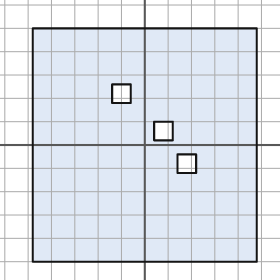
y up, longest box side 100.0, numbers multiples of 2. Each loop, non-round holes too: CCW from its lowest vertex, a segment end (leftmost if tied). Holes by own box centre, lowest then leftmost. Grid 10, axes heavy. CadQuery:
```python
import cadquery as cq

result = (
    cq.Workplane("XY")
    .moveTo(-48.0, -50.0)
    .lineTo(48.0, -50.0)
    .lineTo(48.0, 50.0)
    .lineTo(-48.0, 50.0)
    .close()
    .moveTo(14.0, -12.0)
    .lineTo(22.0, -12.0)
    .lineTo(22.0, -4.0)
    .lineTo(14.0, -4.0)
    .close()
    .moveTo(4.0, 2.0)
    .lineTo(12.0, 2.0)
    .lineTo(12.0, 10.0)
    .lineTo(4.0, 10.0)
    .close()
    .moveTo(-14.0, 18.0)
    .lineTo(-6.0, 18.0)
    .lineTo(-6.0, 26.0)
    .lineTo(-14.0, 26.0)
    .close()
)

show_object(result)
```